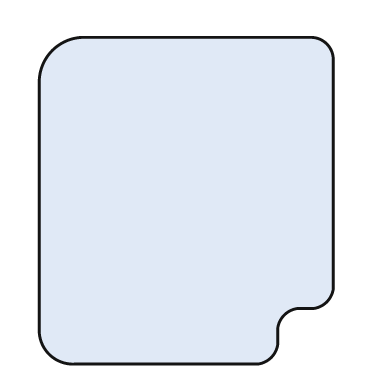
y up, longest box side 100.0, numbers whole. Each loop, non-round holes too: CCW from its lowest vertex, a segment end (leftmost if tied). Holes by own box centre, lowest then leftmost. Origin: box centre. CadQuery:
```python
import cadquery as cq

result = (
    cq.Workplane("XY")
    .moveTo(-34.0, -50.0)
    .lineTo(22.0, -50.0)
    .threePointArc((26.0, -48.0), (28.0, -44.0))
    .lineTo(28.0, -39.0)
    .threePointArc((30.0, -35.0), (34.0, -33.0))
    .lineTo(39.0, -33.0)
    .threePointArc((43.0, -31.0), (45.0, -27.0))
    .lineTo(45.0, 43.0)
    .threePointArc((43.0, 48.0), (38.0, 50.0))
    .lineTo(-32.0, 50.0)
    .threePointArc((-41.0, 46.0), (-45.0, 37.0))
    .lineTo(-45.0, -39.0)
    .threePointArc((-42.0, -47.0), (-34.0, -50.0))
    .close()
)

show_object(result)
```